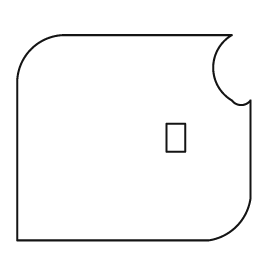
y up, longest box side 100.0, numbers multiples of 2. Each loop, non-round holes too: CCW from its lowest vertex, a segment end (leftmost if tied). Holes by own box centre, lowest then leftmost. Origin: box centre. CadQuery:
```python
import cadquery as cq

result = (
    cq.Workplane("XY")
    .moveTo(-50.0, -44.0)
    .lineTo(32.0, -44.0)
    .threePointArc((44.0, -38.0), (50.0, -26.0))
    .lineTo(50.0, 16.0)
    .threePointArc((46.0, 14.0), (42.0, 16.0))
    .threePointArc((34.0, 30.0), (42.0, 44.0))
    .lineTo(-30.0, 44.0)
    .threePointArc((-44.0, 38.0), (-50.0, 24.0))
    .close()
    .moveTo(14.0, -6.0)
    .lineTo(22.0, -6.0)
    .lineTo(22.0, 6.0)
    .lineTo(14.0, 6.0)
    .close()
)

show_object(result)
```